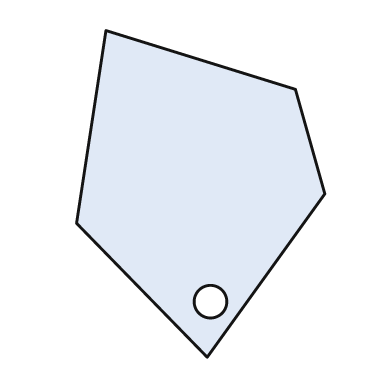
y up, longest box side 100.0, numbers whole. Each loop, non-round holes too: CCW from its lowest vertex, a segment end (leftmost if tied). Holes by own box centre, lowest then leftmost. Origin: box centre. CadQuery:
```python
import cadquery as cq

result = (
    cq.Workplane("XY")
    .moveTo(2.0, -50.0)
    .lineTo(38.0, 0.0)
    .lineTo(29.0, 32.0)
    .lineTo(-29.0, 50.0)
    .lineTo(-38.0, -9.0)
    .close()
    .moveTo(3.0, -33.0)
    .circle(5.0)
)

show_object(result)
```